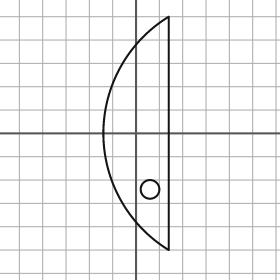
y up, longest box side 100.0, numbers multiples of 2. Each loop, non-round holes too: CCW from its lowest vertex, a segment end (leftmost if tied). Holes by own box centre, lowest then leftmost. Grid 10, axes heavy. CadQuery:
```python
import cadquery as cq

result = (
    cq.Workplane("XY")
    .moveTo(14.0, -50.0)
    .lineTo(14.0, 50.0)
    .threePointArc((-14.0, 0.0), (14.0, -50.0))
    .close()
    .moveTo(6.0, -24.0)
    .circle(4.0)
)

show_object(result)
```